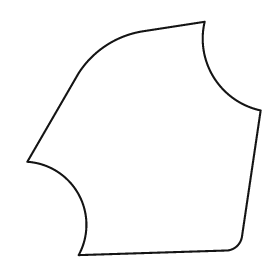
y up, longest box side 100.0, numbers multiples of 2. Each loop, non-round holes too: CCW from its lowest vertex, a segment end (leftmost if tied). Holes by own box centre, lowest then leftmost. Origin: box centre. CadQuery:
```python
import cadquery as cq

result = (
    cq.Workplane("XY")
    .moveTo(-28.0, -50.0)
    .lineTo(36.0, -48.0)
    .threePointArc((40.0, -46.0), (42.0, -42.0))
    .lineTo(50.0, 12.0)
    .threePointArc((30.0, 26.0), (26.0, 50.0))
    .lineTo(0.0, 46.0)
    .threePointArc((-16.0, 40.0), (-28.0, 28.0))
    .lineTo(-50.0, -10.0)
    .threePointArc((-28.0, -24.0), (-28.0, -50.0))
    .close()
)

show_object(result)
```